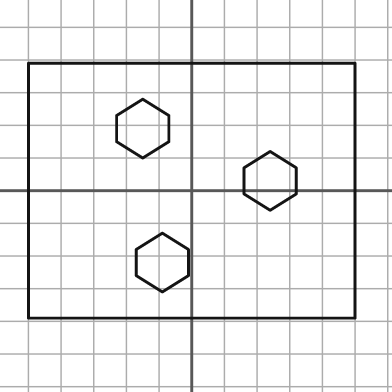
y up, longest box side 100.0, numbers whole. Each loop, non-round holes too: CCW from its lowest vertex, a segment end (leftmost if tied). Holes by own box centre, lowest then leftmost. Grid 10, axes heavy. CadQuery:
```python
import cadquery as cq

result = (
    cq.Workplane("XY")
    .moveTo(-50.0, -39.0)
    .lineTo(50.0, -39.0)
    .lineTo(50.0, 39.0)
    .lineTo(-50.0, 39.0)
    .close()
    .moveTo(-9.0, -31.0)
    .lineTo(-1.0, -26.0)
    .lineTo(-1.0, -18.0)
    .lineTo(-9.0, -13.0)
    .lineTo(-17.0, -18.0)
    .lineTo(-17.0, -26.0)
    .close()
    .moveTo(24.0, -6.0)
    .lineTo(32.0, -1.0)
    .lineTo(32.0, 7.0)
    .lineTo(24.0, 12.0)
    .lineTo(16.0, 7.0)
    .lineTo(16.0, -1.0)
    .close()
    .moveTo(-15.0, 10.0)
    .lineTo(-7.0, 15.0)
    .lineTo(-7.0, 23.0)
    .lineTo(-15.0, 28.0)
    .lineTo(-23.0, 23.0)
    .lineTo(-23.0, 15.0)
    .close()
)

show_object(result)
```